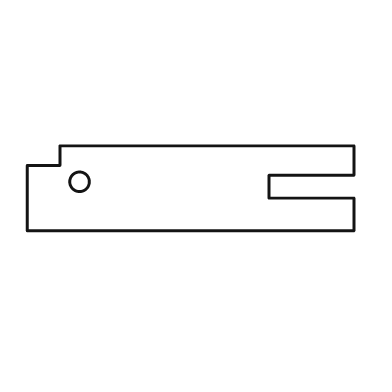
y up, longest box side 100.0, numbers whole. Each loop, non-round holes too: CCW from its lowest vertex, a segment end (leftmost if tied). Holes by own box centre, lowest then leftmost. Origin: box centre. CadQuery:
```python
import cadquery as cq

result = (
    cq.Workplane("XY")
    .moveTo(-50.0, -13.0)
    .lineTo(50.0, -13.0)
    .lineTo(50.0, -3.0)
    .lineTo(24.0, -3.0)
    .lineTo(24.0, 4.0)
    .lineTo(50.0, 4.0)
    .lineTo(50.0, 13.0)
    .lineTo(-40.0, 13.0)
    .lineTo(-40.0, 7.0)
    .lineTo(-50.0, 7.0)
    .close()
    .moveTo(-34.0, 2.0)
    .circle(3.0)
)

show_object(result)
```